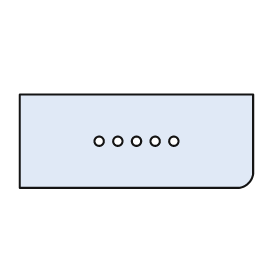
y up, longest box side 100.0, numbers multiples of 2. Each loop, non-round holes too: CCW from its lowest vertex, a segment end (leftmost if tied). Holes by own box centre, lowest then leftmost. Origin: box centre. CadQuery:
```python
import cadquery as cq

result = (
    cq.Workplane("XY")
    .moveTo(-50.0, -20.0)
    .lineTo(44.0, -20.0)
    .threePointArc((48.0, -18.0), (50.0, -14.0))
    .lineTo(50.0, 20.0)
    .lineTo(-50.0, 20.0)
    .close()
    .moveTo(-16.0, 0.0)
    .circle(2.0)
    .moveTo(-8.0, 0.0)
    .circle(2.0)
    .moveTo(0.0, 0.0)
    .circle(2.0)
    .moveTo(8.0, 0.0)
    .circle(2.0)
    .moveTo(16.0, 0.0)
    .circle(2.0)
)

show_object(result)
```